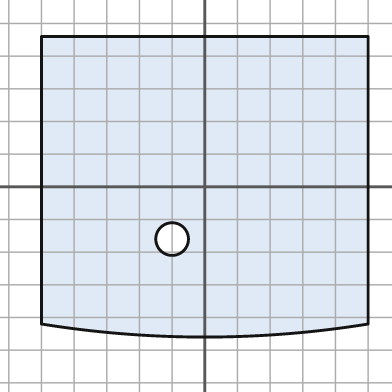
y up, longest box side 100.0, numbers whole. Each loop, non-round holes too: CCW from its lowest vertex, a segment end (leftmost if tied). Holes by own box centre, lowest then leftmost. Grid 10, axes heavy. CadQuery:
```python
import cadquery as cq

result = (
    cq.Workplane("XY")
    .moveTo(-50.0, -42.0)
    .threePointArc((0.0, -46.0), (50.0, -42.0))
    .lineTo(50.0, 46.0)
    .lineTo(-50.0, 46.0)
    .close()
    .moveTo(-10.0, -16.0)
    .circle(5.0)
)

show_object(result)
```